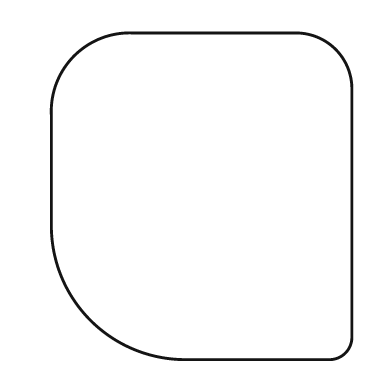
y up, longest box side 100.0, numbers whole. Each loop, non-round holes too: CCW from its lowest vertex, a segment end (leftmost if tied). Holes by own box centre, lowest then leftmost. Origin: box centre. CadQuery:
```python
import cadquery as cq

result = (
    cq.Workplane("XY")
    .moveTo(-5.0, -50.0)
    .lineTo(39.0, -50.0)
    .threePointArc((44.0, -48.0), (46.0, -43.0))
    .lineTo(46.0, 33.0)
    .threePointArc((41.0, 45.0), (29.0, 50.0))
    .lineTo(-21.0, 50.0)
    .threePointArc((-39.0, 43.0), (-46.0, 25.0))
    .lineTo(-46.0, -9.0)
    .threePointArc((-34.0, -38.0), (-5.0, -50.0))
    .close()
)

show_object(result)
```